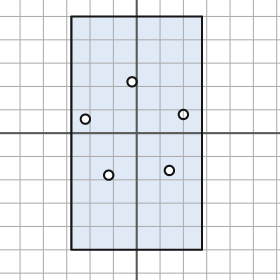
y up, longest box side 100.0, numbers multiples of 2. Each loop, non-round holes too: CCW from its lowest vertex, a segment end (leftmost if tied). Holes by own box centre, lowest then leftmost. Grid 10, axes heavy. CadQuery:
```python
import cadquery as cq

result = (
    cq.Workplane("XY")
    .moveTo(-28.0, -50.0)
    .lineTo(28.0, -50.0)
    .lineTo(28.0, 50.0)
    .lineTo(-28.0, 50.0)
    .close()
    .moveTo(-12.0, -18.0)
    .circle(2.0)
    .moveTo(14.0, -16.0)
    .circle(2.0)
    .moveTo(-22.0, 6.0)
    .circle(2.0)
    .moveTo(20.0, 8.0)
    .circle(2.0)
    .moveTo(-2.0, 22.0)
    .circle(2.0)
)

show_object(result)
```